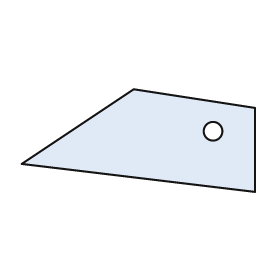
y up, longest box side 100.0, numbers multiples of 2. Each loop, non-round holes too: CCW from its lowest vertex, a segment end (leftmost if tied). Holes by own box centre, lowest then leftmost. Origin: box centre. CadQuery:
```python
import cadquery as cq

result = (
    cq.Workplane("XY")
    .moveTo(50.0, -22.0)
    .lineTo(50.0, 14.0)
    .lineTo(-2.0, 22.0)
    .lineTo(-50.0, -10.0)
    .close()
    .moveTo(32.0, 4.0)
    .circle(4.0)
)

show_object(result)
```